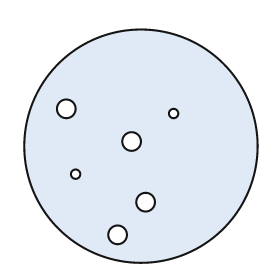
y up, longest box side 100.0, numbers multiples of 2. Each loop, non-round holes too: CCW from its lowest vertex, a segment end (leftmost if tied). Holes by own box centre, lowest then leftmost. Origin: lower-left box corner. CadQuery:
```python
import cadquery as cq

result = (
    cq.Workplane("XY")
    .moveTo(50.0, 50.0)
    .circle(50.0)
    .moveTo(40.0, 12.0)
    .circle(4.0)
    .moveTo(52.0, 26.0)
    .circle(4.0)
    .moveTo(22.0, 38.0)
    .circle(2.0)
    .moveTo(46.0, 52.0)
    .circle(4.0)
    .moveTo(64.0, 64.0)
    .circle(2.0)
    .moveTo(18.0, 66.0)
    .circle(4.0)
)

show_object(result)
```